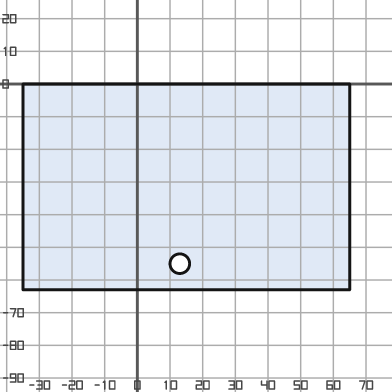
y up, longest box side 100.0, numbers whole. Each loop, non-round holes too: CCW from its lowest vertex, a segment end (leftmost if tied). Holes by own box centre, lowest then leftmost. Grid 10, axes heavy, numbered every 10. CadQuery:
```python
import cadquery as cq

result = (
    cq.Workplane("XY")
    .moveTo(-35.0, -63.0)
    .lineTo(65.0, -63.0)
    .lineTo(65.0, 0.0)
    .lineTo(-35.0, 0.0)
    .close()
    .moveTo(13.0, -55.0)
    .circle(3.0)
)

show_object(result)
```